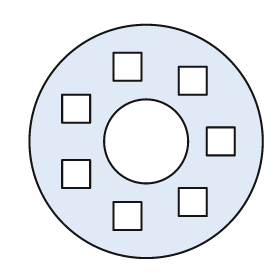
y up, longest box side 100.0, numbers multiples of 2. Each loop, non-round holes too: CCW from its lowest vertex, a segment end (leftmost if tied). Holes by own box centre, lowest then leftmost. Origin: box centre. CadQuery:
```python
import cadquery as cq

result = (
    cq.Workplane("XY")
    .moveTo(0.0, 0.0)
    .circle(50.0)
    .moveTo(-14.0, -38.0)
    .lineTo(-2.0, -38.0)
    .lineTo(-2.0, -26.0)
    .lineTo(-14.0, -26.0)
    .close()
    .moveTo(14.0, -32.0)
    .lineTo(26.0, -32.0)
    .lineTo(26.0, -20.0)
    .lineTo(14.0, -20.0)
    .close()
    .moveTo(-36.0, -20.0)
    .lineTo(-24.0, -20.0)
    .lineTo(-24.0, -8.0)
    .lineTo(-36.0, -8.0)
    .close()
    .moveTo(0.0, 0.0)
    .circle(18.0)
    .moveTo(26.0, -6.0)
    .lineTo(38.0, -6.0)
    .lineTo(38.0, 6.0)
    .lineTo(26.0, 6.0)
    .close()
    .moveTo(-36.0, 8.0)
    .lineTo(-24.0, 8.0)
    .lineTo(-24.0, 20.0)
    .lineTo(-36.0, 20.0)
    .close()
    .moveTo(14.0, 20.0)
    .lineTo(26.0, 20.0)
    .lineTo(26.0, 32.0)
    .lineTo(14.0, 32.0)
    .close()
    .moveTo(-14.0, 26.0)
    .lineTo(-2.0, 26.0)
    .lineTo(-2.0, 38.0)
    .lineTo(-14.0, 38.0)
    .close()
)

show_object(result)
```